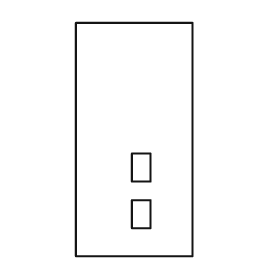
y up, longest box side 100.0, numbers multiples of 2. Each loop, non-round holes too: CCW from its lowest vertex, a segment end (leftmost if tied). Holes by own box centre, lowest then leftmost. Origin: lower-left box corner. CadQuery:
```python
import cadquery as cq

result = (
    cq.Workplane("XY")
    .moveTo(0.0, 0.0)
    .lineTo(50.0, 0.0)
    .lineTo(50.0, 100.0)
    .lineTo(0.0, 100.0)
    .close()
    .moveTo(24.0, 12.0)
    .lineTo(32.0, 12.0)
    .lineTo(32.0, 24.0)
    .lineTo(24.0, 24.0)
    .close()
    .moveTo(24.0, 32.0)
    .lineTo(32.0, 32.0)
    .lineTo(32.0, 44.0)
    .lineTo(24.0, 44.0)
    .close()
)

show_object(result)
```